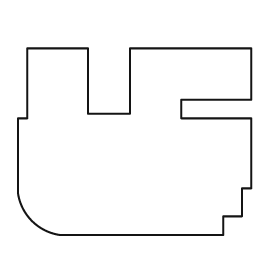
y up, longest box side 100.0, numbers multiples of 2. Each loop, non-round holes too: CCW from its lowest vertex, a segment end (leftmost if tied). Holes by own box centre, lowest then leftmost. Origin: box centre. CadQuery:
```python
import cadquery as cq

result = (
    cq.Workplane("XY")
    .moveTo(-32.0, -40.0)
    .lineTo(38.0, -40.0)
    .lineTo(38.0, -32.0)
    .lineTo(46.0, -32.0)
    .lineTo(46.0, -20.0)
    .lineTo(50.0, -20.0)
    .lineTo(50.0, 10.0)
    .lineTo(20.0, 10.0)
    .lineTo(20.0, 18.0)
    .lineTo(50.0, 18.0)
    .lineTo(50.0, 40.0)
    .lineTo(-2.0, 40.0)
    .lineTo(-2.0, 12.0)
    .lineTo(-20.0, 12.0)
    .lineTo(-20.0, 40.0)
    .lineTo(-46.0, 40.0)
    .lineTo(-46.0, 10.0)
    .lineTo(-50.0, 10.0)
    .lineTo(-50.0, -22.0)
    .threePointArc((-44.0, -34.0), (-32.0, -40.0))
    .close()
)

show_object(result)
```